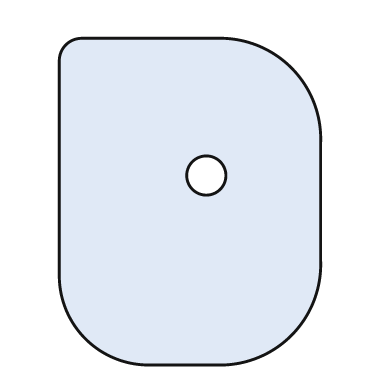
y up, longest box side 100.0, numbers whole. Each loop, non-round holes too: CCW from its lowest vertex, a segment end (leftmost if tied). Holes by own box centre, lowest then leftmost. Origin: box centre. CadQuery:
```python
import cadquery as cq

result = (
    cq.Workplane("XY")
    .moveTo(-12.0, -50.0)
    .lineTo(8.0, -50.0)
    .threePointArc((31.0, -41.0), (40.0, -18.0))
    .lineTo(40.0, 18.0)
    .threePointArc((31.0, 41.0), (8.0, 50.0))
    .lineTo(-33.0, 50.0)
    .threePointArc((-38.0, 48.0), (-40.0, 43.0))
    .lineTo(-40.0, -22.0)
    .threePointArc((-32.0, -42.0), (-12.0, -50.0))
    .close()
    .moveTo(5.0, 8.0)
    .circle(6.0)
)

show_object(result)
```